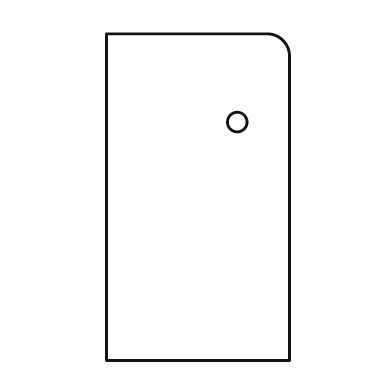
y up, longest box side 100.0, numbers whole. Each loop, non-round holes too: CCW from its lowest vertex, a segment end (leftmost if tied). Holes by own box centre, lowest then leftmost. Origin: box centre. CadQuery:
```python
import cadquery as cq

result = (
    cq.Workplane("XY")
    .moveTo(-28.0, -50.0)
    .lineTo(28.0, -50.0)
    .lineTo(28.0, 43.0)
    .threePointArc((26.0, 48.0), (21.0, 50.0))
    .lineTo(-28.0, 50.0)
    .close()
    .moveTo(12.0, 23.0)
    .circle(3.0)
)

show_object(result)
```